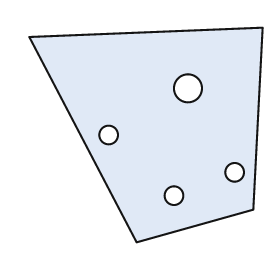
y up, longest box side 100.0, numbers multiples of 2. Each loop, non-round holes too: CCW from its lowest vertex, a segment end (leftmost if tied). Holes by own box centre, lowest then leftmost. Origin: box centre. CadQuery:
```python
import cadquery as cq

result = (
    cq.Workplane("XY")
    .moveTo(-4.0, -46.0)
    .lineTo(46.0, -32.0)
    .lineTo(50.0, 46.0)
    .lineTo(-50.0, 42.0)
    .close()
    .moveTo(12.0, -26.0)
    .circle(4.0)
    .moveTo(38.0, -16.0)
    .circle(4.0)
    .moveTo(-16.0, 0.0)
    .circle(4.0)
    .moveTo(18.0, 20.0)
    .circle(6.0)
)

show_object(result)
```